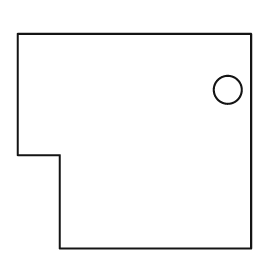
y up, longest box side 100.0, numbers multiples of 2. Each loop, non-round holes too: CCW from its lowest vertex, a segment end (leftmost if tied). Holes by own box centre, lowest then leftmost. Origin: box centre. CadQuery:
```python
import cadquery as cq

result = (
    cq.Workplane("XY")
    .moveTo(-32.0, -46.0)
    .lineTo(50.0, -46.0)
    .lineTo(50.0, 46.0)
    .lineTo(-50.0, 46.0)
    .lineTo(-50.0, -6.0)
    .lineTo(-32.0, -6.0)
    .close()
    .moveTo(40.0, 22.0)
    .circle(6.0)
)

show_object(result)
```